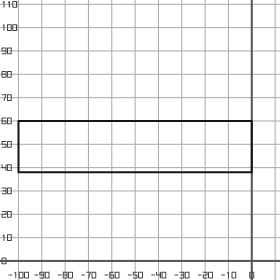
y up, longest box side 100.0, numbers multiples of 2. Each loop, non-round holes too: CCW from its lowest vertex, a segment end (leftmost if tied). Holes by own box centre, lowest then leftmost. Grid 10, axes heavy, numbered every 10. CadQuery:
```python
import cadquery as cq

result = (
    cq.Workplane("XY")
    .moveTo(-100.0, 38.0)
    .lineTo(0.0, 38.0)
    .lineTo(0.0, 60.0)
    .lineTo(-100.0, 60.0)
    .close()
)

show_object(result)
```